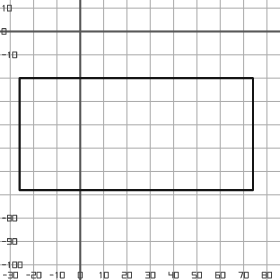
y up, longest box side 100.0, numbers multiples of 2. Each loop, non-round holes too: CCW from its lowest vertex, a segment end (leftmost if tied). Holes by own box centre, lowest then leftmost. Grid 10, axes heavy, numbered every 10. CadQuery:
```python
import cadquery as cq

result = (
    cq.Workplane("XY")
    .moveTo(-26.0, -68.0)
    .lineTo(74.0, -68.0)
    .lineTo(74.0, -20.0)
    .lineTo(-26.0, -20.0)
    .close()
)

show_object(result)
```